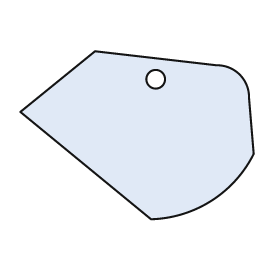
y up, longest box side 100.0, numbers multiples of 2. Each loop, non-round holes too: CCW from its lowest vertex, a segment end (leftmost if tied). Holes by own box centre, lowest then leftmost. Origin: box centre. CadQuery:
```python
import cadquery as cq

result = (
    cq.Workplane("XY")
    .moveTo(6.0, -36.0)
    .threePointArc((32.0, -28.0), (50.0, -8.0))
    .lineTo(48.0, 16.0)
    .threePointArc((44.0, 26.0), (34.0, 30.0))
    .lineTo(-18.0, 36.0)
    .lineTo(-50.0, 10.0)
    .close()
    .moveTo(8.0, 24.0)
    .circle(4.0)
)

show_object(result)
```